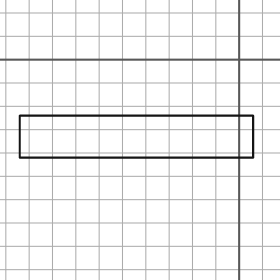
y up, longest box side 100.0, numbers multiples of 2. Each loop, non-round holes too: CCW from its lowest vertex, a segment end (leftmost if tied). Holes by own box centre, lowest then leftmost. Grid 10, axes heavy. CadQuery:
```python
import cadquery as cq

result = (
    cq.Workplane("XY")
    .moveTo(-94.0, -42.0)
    .lineTo(6.0, -42.0)
    .lineTo(6.0, -24.0)
    .lineTo(-94.0, -24.0)
    .close()
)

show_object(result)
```